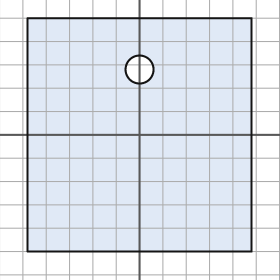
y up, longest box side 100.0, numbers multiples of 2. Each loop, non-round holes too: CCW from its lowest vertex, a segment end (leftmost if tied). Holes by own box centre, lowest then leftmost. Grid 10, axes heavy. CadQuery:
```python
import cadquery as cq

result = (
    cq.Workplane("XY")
    .moveTo(-48.0, -50.0)
    .lineTo(48.0, -50.0)
    .lineTo(48.0, 50.0)
    .lineTo(-48.0, 50.0)
    .close()
    .moveTo(0.0, 28.0)
    .circle(6.0)
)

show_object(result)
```